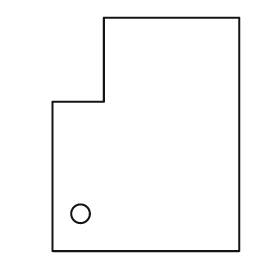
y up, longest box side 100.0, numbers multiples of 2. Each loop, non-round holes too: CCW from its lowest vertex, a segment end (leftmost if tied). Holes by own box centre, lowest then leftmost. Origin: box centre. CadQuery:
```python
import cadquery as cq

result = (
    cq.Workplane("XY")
    .moveTo(-40.0, -50.0)
    .lineTo(40.0, -50.0)
    .lineTo(40.0, 50.0)
    .lineTo(-18.0, 50.0)
    .lineTo(-18.0, 14.0)
    .lineTo(-40.0, 14.0)
    .close()
    .moveTo(-28.0, -34.0)
    .circle(4.0)
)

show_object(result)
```